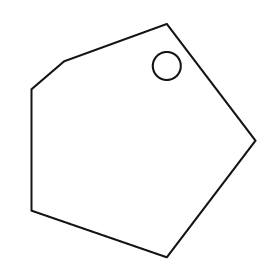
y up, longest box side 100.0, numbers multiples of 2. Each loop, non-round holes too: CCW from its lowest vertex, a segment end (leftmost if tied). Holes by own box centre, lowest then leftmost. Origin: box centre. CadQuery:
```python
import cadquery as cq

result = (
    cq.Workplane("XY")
    .moveTo(10.0, -50.0)
    .lineTo(48.0, 0.0)
    .lineTo(10.0, 50.0)
    .lineTo(-34.0, 34.0)
    .lineTo(-48.0, 22.0)
    .lineTo(-48.0, -30.0)
    .close()
    .moveTo(10.0, 32.0)
    .circle(6.0)
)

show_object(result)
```